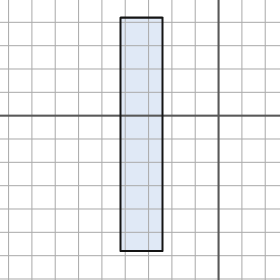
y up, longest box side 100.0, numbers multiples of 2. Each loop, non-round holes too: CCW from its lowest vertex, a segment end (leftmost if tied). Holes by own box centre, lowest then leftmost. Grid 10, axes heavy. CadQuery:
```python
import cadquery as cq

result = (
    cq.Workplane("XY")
    .moveTo(-42.0, -58.0)
    .lineTo(-24.0, -58.0)
    .lineTo(-24.0, 42.0)
    .lineTo(-42.0, 42.0)
    .close()
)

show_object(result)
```